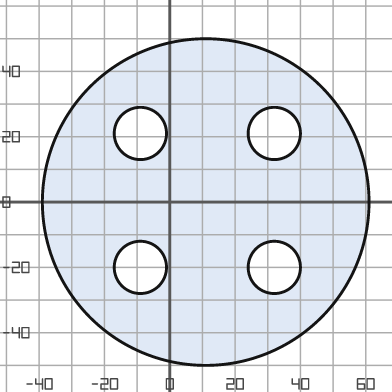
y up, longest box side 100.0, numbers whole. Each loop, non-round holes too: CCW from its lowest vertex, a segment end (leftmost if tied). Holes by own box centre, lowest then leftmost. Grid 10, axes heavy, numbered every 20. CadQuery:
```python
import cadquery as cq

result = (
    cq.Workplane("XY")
    .moveTo(11.0, 0.0)
    .circle(50.0)
    .moveTo(-9.0, -20.0)
    .circle(8.0)
    .moveTo(32.0, -20.0)
    .circle(8.0)
    .moveTo(-9.0, 21.0)
    .circle(8.0)
    .moveTo(32.0, 21.0)
    .circle(8.0)
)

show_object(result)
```